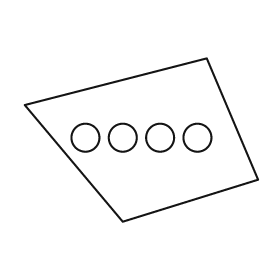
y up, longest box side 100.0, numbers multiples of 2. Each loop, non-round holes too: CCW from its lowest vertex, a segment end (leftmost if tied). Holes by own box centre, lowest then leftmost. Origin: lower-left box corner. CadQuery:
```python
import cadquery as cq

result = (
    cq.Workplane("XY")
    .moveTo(42.0, 0.0)
    .lineTo(100.0, 18.0)
    .lineTo(78.0, 70.0)
    .lineTo(0.0, 50.0)
    .close()
    .moveTo(26.0, 36.0)
    .circle(6.0)
    .moveTo(42.0, 36.0)
    .circle(6.0)
    .moveTo(58.0, 36.0)
    .circle(6.0)
    .moveTo(74.0, 36.0)
    .circle(6.0)
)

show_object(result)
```